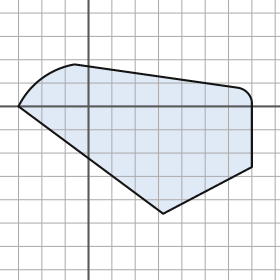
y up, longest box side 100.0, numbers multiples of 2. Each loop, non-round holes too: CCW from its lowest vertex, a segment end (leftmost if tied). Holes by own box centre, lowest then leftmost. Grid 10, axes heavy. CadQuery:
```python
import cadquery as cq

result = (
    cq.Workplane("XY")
    .moveTo(32.0, -46.0)
    .lineTo(70.0, -26.0)
    .lineTo(70.0, 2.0)
    .threePointArc((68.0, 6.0), (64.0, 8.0))
    .lineTo(-6.0, 18.0)
    .threePointArc((-20.0, 12.0), (-30.0, 0.0))
    .close()
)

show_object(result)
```